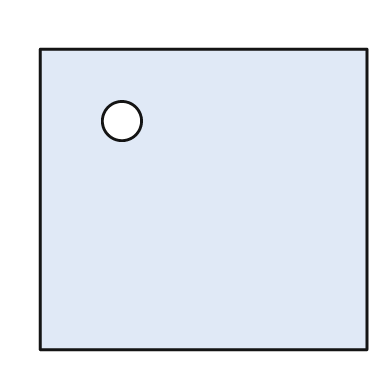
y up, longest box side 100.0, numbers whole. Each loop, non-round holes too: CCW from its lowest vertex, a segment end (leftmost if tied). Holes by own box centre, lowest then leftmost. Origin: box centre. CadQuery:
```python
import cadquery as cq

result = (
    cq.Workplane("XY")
    .moveTo(-50.0, -46.0)
    .lineTo(50.0, -46.0)
    .lineTo(50.0, 46.0)
    .lineTo(-50.0, 46.0)
    .close()
    .moveTo(-25.0, 24.0)
    .circle(6.0)
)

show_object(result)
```